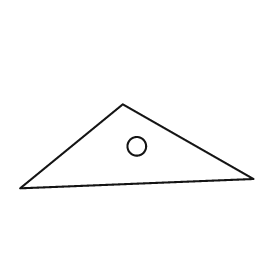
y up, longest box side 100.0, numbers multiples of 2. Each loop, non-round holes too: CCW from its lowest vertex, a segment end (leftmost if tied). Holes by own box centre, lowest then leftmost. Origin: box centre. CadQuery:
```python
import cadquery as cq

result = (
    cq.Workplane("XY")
    .moveTo(-50.0, -18.0)
    .lineTo(50.0, -14.0)
    .lineTo(-6.0, 18.0)
    .close()
    .moveTo(0.0, 0.0)
    .circle(4.0)
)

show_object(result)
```